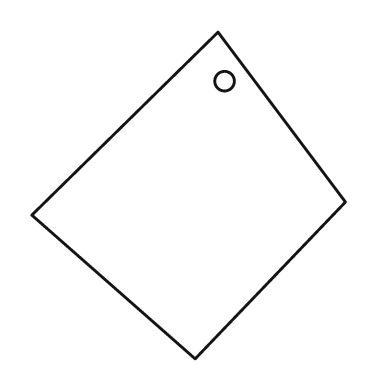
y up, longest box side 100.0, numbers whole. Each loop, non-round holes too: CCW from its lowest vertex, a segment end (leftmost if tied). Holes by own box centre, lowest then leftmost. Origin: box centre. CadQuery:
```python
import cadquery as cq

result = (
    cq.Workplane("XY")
    .moveTo(2.0, -50.0)
    .lineTo(48.0, -2.0)
    .lineTo(9.0, 50.0)
    .lineTo(-48.0, -6.0)
    .close()
    .moveTo(11.0, 35.0)
    .circle(3.0)
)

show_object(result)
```